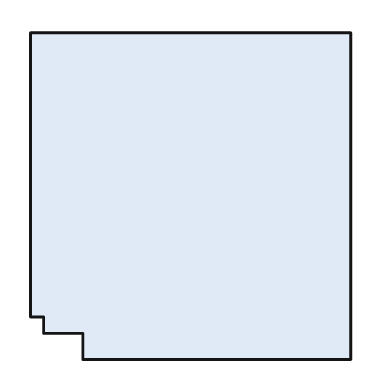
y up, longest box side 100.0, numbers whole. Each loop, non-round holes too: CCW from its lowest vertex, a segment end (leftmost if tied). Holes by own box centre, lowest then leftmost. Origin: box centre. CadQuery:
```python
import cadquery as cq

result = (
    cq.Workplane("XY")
    .moveTo(-33.0, -50.0)
    .lineTo(49.0, -50.0)
    .lineTo(49.0, 50.0)
    .lineTo(-49.0, 50.0)
    .lineTo(-49.0, -37.0)
    .lineTo(-45.0, -37.0)
    .lineTo(-45.0, -42.0)
    .lineTo(-33.0, -42.0)
    .close()
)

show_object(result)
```